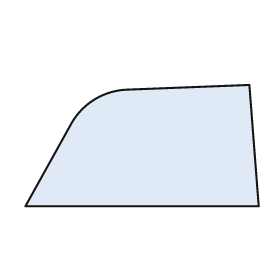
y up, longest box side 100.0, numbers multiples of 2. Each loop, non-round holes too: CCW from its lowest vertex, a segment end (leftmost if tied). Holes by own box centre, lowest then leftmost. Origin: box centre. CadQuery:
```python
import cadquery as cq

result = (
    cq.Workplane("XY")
    .moveTo(-50.0, -26.0)
    .lineTo(50.0, -26.0)
    .lineTo(46.0, 26.0)
    .lineTo(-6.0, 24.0)
    .threePointArc((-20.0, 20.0), (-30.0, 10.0))
    .close()
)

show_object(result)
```